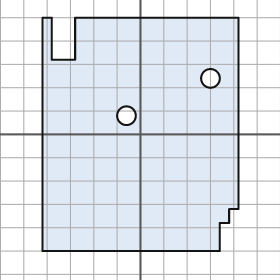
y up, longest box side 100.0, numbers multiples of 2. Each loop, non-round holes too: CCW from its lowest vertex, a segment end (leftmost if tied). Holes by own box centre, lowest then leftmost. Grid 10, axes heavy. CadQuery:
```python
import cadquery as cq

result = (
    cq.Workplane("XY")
    .moveTo(-42.0, -50.0)
    .lineTo(34.0, -50.0)
    .lineTo(34.0, -38.0)
    .lineTo(38.0, -38.0)
    .lineTo(38.0, -32.0)
    .lineTo(42.0, -32.0)
    .lineTo(42.0, 50.0)
    .lineTo(-28.0, 50.0)
    .lineTo(-28.0, 32.0)
    .lineTo(-38.0, 32.0)
    .lineTo(-38.0, 50.0)
    .lineTo(-42.0, 50.0)
    .close()
    .moveTo(-6.0, 8.0)
    .circle(4.0)
    .moveTo(30.0, 24.0)
    .circle(4.0)
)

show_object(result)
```